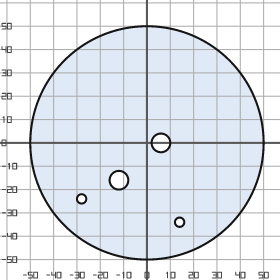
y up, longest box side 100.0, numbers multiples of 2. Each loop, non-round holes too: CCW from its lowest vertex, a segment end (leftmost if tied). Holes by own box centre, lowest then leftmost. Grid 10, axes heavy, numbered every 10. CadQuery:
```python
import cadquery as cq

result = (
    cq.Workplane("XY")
    .moveTo(0.0, 0.0)
    .circle(50.0)
    .moveTo(14.0, -34.0)
    .circle(2.0)
    .moveTo(-28.0, -24.0)
    .circle(2.0)
    .moveTo(-12.0, -16.0)
    .circle(4.0)
    .moveTo(6.0, 0.0)
    .circle(4.0)
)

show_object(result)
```